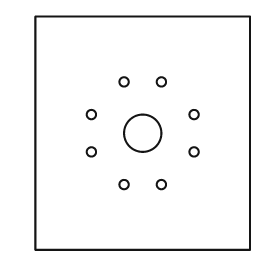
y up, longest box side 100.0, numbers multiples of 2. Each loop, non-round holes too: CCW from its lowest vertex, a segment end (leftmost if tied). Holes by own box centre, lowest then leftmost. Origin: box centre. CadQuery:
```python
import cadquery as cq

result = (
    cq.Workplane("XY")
    .moveTo(-46.0, -50.0)
    .lineTo(46.0, -50.0)
    .lineTo(46.0, 50.0)
    .lineTo(-46.0, 50.0)
    .close()
    .moveTo(-8.0, -22.0)
    .circle(2.0)
    .moveTo(8.0, -22.0)
    .circle(2.0)
    .moveTo(-22.0, -8.0)
    .circle(2.0)
    .moveTo(22.0, -8.0)
    .circle(2.0)
    .moveTo(0.0, 0.0)
    .circle(8.0)
    .moveTo(-22.0, 8.0)
    .circle(2.0)
    .moveTo(22.0, 8.0)
    .circle(2.0)
    .moveTo(-8.0, 22.0)
    .circle(2.0)
    .moveTo(8.0, 22.0)
    .circle(2.0)
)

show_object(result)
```